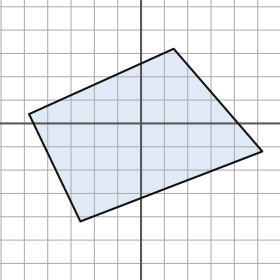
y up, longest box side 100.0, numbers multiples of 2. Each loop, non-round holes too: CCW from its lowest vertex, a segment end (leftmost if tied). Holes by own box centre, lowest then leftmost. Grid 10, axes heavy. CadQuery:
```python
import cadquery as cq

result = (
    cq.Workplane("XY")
    .moveTo(-26.0, -42.0)
    .lineTo(52.0, -12.0)
    .lineTo(14.0, 32.0)
    .lineTo(-48.0, 4.0)
    .close()
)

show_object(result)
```